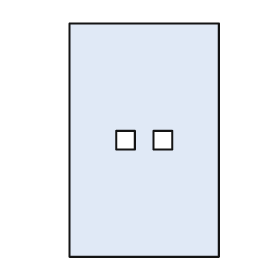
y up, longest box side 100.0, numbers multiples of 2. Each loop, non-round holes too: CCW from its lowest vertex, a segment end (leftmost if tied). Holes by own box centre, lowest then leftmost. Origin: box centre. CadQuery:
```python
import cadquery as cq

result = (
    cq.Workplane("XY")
    .moveTo(-32.0, -50.0)
    .lineTo(32.0, -50.0)
    .lineTo(32.0, 50.0)
    .lineTo(-32.0, 50.0)
    .close()
    .moveTo(-12.0, -4.0)
    .lineTo(-4.0, -4.0)
    .lineTo(-4.0, 4.0)
    .lineTo(-12.0, 4.0)
    .close()
    .moveTo(4.0, -4.0)
    .lineTo(12.0, -4.0)
    .lineTo(12.0, 4.0)
    .lineTo(4.0, 4.0)
    .close()
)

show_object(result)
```